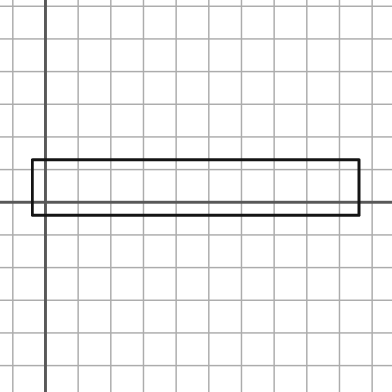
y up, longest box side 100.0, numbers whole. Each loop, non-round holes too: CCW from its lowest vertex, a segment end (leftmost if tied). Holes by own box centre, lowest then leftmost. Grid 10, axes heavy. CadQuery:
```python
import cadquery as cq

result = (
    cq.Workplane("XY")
    .moveTo(-4.0, -4.0)
    .lineTo(96.0, -4.0)
    .lineTo(96.0, 13.0)
    .lineTo(-4.0, 13.0)
    .close()
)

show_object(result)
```